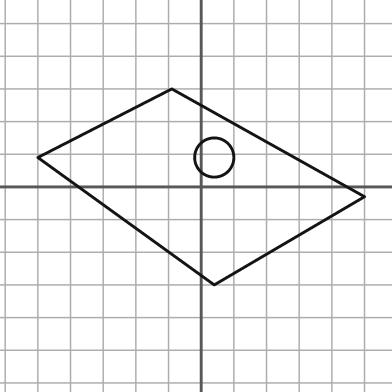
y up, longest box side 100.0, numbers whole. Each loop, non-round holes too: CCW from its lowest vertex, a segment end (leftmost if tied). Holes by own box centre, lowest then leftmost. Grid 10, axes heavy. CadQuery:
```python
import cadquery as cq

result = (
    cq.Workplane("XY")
    .moveTo(4.0, -30.0)
    .lineTo(50.0, -3.0)
    .lineTo(-9.0, 30.0)
    .lineTo(-50.0, 9.0)
    .close()
    .moveTo(4.0, 9.0)
    .circle(6.0)
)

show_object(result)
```